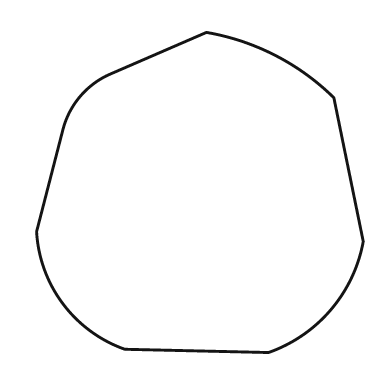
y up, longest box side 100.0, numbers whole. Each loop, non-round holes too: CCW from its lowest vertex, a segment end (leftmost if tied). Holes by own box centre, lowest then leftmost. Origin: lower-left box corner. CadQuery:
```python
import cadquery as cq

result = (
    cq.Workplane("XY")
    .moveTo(71.0, 0.0)
    .threePointArc((90.0, 13.0), (100.0, 34.0))
    .lineTo(91.0, 78.0)
    .threePointArc((73.0, 91.0), (52.0, 98.0))
    .lineTo(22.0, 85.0)
    .threePointArc((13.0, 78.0), (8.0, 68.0))
    .lineTo(0.0, 37.0)
    .threePointArc((8.0, 15.0), (27.0, 1.0))
    .close()
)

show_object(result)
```